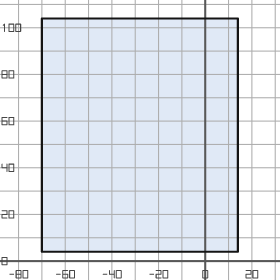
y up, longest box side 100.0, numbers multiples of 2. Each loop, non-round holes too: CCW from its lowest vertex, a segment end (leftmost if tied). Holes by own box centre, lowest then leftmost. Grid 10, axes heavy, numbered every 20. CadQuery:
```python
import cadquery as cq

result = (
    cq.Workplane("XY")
    .moveTo(-70.0, 4.0)
    .lineTo(14.0, 4.0)
    .lineTo(14.0, 104.0)
    .lineTo(-70.0, 104.0)
    .close()
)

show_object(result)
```